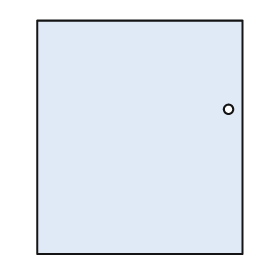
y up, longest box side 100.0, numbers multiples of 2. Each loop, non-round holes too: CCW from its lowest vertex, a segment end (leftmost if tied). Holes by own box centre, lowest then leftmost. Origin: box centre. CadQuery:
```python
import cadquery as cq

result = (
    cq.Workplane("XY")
    .moveTo(-44.0, -50.0)
    .lineTo(44.0, -50.0)
    .lineTo(44.0, 50.0)
    .lineTo(-44.0, 50.0)
    .close()
    .moveTo(38.0, 12.0)
    .circle(2.0)
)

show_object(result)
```